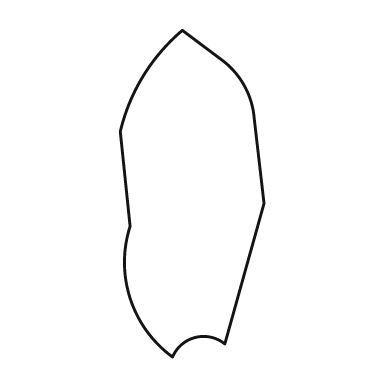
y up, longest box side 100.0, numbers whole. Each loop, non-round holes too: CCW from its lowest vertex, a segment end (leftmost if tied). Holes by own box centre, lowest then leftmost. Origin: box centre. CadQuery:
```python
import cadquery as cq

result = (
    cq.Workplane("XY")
    .moveTo(-6.0, -50.0)
    .threePointArc((1.0, -44.0), (10.0, -46.0))
    .lineTo(22.0, -3.0)
    .lineTo(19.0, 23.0)
    .threePointArc((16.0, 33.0), (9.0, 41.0))
    .lineTo(-3.0, 50.0)
    .threePointArc((-15.0, 36.0), (-22.0, 19.0))
    .lineTo(-19.0, -10.0)
    .threePointArc((-19.0, -32.0), (-6.0, -50.0))
    .close()
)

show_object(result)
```